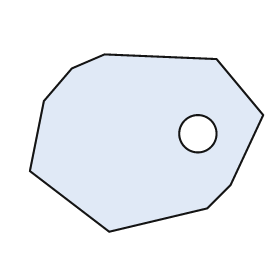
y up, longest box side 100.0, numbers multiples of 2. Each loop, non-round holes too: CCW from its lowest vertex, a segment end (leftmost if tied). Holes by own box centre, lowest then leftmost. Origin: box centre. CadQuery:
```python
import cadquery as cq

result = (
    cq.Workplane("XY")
    .moveTo(-16.0, -38.0)
    .lineTo(26.0, -28.0)
    .lineTo(36.0, -18.0)
    .lineTo(50.0, 12.0)
    .lineTo(30.0, 36.0)
    .lineTo(-18.0, 38.0)
    .lineTo(-32.0, 32.0)
    .lineTo(-44.0, 18.0)
    .lineTo(-50.0, -12.0)
    .close()
    .moveTo(22.0, 4.0)
    .circle(8.0)
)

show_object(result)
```